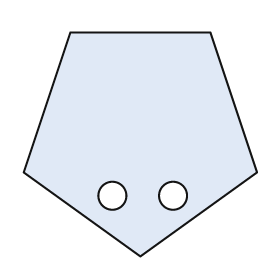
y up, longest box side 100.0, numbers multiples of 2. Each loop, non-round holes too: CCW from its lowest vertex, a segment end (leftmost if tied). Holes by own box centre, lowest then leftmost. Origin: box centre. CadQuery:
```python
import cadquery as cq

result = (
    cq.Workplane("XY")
    .moveTo(0.0, -48.0)
    .lineTo(50.0, -12.0)
    .lineTo(30.0, 48.0)
    .lineTo(-30.0, 48.0)
    .lineTo(-50.0, -12.0)
    .close()
    .moveTo(-12.0, -22.0)
    .circle(6.0)
    .moveTo(14.0, -22.0)
    .circle(6.0)
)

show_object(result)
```